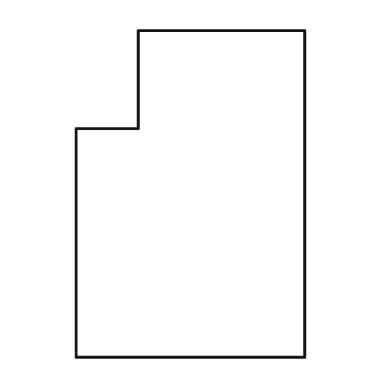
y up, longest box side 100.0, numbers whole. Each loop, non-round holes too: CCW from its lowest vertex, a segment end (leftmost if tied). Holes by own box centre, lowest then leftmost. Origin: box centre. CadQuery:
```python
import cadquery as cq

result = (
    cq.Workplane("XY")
    .moveTo(-35.0, -50.0)
    .lineTo(35.0, -50.0)
    .lineTo(35.0, 50.0)
    .lineTo(-16.0, 50.0)
    .lineTo(-16.0, 20.0)
    .lineTo(-35.0, 20.0)
    .close()
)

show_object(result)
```